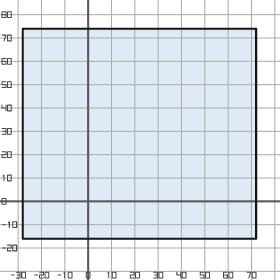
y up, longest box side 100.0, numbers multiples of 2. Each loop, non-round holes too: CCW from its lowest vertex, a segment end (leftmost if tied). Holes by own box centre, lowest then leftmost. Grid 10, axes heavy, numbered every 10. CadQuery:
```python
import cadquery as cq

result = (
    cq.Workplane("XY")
    .moveTo(-28.0, -16.0)
    .lineTo(72.0, -16.0)
    .lineTo(72.0, 74.0)
    .lineTo(-28.0, 74.0)
    .close()
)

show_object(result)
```